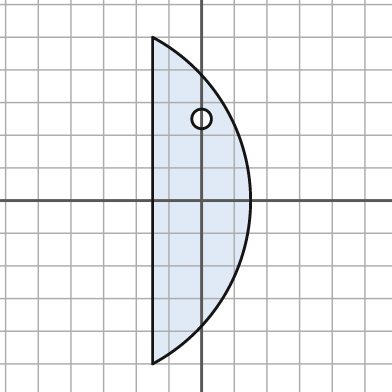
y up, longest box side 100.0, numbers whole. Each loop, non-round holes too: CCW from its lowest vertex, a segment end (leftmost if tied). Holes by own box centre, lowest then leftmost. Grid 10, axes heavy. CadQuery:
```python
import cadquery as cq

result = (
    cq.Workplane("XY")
    .moveTo(-15.0, -50.0)
    .threePointArc((15.0, 0.0), (-15.0, 50.0))
    .close()
    .moveTo(0.0, 25.0)
    .circle(3.0)
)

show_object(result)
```